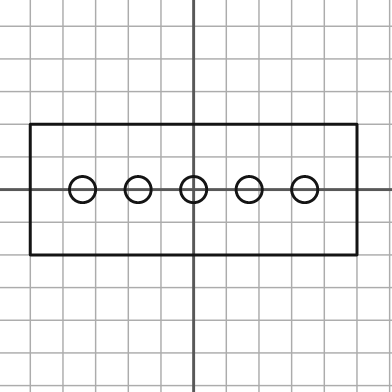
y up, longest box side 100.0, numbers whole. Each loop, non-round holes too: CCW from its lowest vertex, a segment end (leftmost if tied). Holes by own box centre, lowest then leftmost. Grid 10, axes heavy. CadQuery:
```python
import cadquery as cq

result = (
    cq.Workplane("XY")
    .moveTo(-50.0, -20.0)
    .lineTo(50.0, -20.0)
    .lineTo(50.0, 20.0)
    .lineTo(-50.0, 20.0)
    .close()
    .moveTo(-34.0, 0.0)
    .circle(4.0)
    .moveTo(-17.0, 0.0)
    .circle(4.0)
    .moveTo(0.0, 0.0)
    .circle(4.0)
    .moveTo(17.0, 0.0)
    .circle(4.0)
    .moveTo(34.0, 0.0)
    .circle(4.0)
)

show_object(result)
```